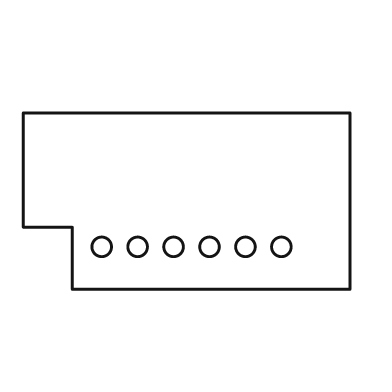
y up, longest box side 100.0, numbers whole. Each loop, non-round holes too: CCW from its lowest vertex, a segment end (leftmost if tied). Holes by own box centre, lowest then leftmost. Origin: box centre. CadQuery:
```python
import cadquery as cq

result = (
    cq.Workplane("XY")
    .moveTo(-35.0, -27.0)
    .lineTo(50.0, -27.0)
    .lineTo(50.0, 27.0)
    .lineTo(-50.0, 27.0)
    .lineTo(-50.0, -8.0)
    .lineTo(-35.0, -8.0)
    .close()
    .moveTo(-26.0, -14.0)
    .circle(3.0)
    .moveTo(-15.0, -14.0)
    .circle(3.0)
    .moveTo(-4.0, -14.0)
    .circle(3.0)
    .moveTo(7.0, -14.0)
    .circle(3.0)
    .moveTo(18.0, -14.0)
    .circle(3.0)
    .moveTo(29.0, -14.0)
    .circle(3.0)
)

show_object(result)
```